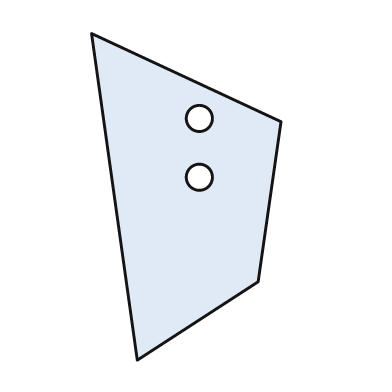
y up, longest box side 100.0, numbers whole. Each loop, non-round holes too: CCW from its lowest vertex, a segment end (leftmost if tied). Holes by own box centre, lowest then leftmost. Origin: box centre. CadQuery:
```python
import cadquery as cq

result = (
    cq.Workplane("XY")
    .moveTo(-15.0, -50.0)
    .lineTo(22.0, -26.0)
    .lineTo(29.0, 23.0)
    .lineTo(-29.0, 50.0)
    .close()
    .moveTo(4.0, 6.0)
    .circle(4.0)
    .moveTo(4.0, 24.0)
    .circle(4.0)
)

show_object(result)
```